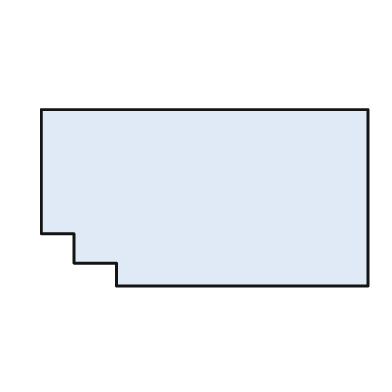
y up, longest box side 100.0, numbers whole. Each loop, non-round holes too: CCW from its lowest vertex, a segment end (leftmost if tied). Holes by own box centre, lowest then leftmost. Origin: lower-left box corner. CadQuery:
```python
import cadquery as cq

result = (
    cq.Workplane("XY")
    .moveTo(23.0, 0.0)
    .lineTo(100.0, 0.0)
    .lineTo(100.0, 54.0)
    .lineTo(0.0, 54.0)
    .lineTo(0.0, 16.0)
    .lineTo(10.0, 16.0)
    .lineTo(10.0, 7.0)
    .lineTo(23.0, 7.0)
    .close()
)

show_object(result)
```